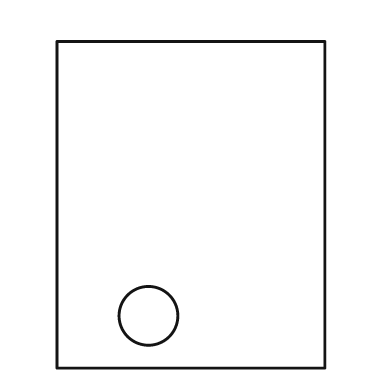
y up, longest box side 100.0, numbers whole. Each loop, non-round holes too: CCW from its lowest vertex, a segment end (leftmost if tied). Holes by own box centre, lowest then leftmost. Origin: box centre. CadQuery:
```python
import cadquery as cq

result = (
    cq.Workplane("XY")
    .moveTo(-41.0, -50.0)
    .lineTo(41.0, -50.0)
    .lineTo(41.0, 50.0)
    .lineTo(-41.0, 50.0)
    .close()
    .moveTo(-13.0, -34.0)
    .circle(9.0)
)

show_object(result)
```